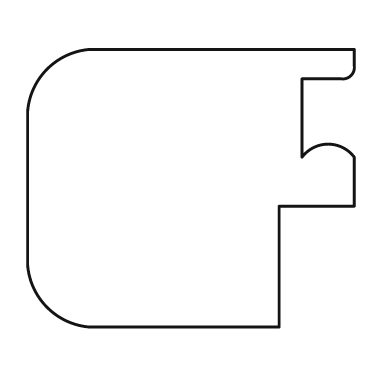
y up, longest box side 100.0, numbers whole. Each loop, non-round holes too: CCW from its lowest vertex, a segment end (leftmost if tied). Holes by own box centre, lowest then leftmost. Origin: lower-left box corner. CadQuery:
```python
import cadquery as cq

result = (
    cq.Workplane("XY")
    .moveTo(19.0, 0.0)
    .lineTo(77.0, 0.0)
    .lineTo(77.0, 37.0)
    .lineTo(100.0, 37.0)
    .lineTo(100.0, 52.0)
    .threePointArc((92.0, 56.0), (84.0, 52.0))
    .lineTo(84.0, 76.0)
    .lineTo(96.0, 76.0)
    .threePointArc((99.0, 77.0), (100.0, 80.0))
    .lineTo(100.0, 85.0)
    .lineTo(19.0, 85.0)
    .threePointArc((6.0, 79.0), (0.0, 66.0))
    .lineTo(0.0, 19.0)
    .threePointArc((6.0, 6.0), (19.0, 0.0))
    .close()
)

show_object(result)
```